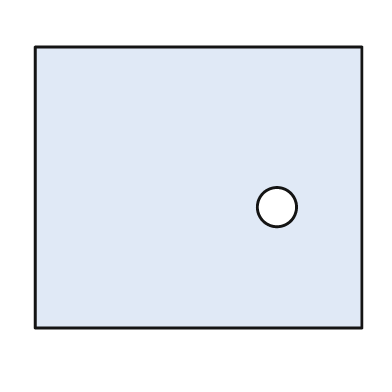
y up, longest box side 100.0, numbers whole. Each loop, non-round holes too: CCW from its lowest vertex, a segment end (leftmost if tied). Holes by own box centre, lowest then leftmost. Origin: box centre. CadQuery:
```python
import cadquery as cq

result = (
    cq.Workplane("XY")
    .moveTo(-50.0, -43.0)
    .lineTo(50.0, -43.0)
    .lineTo(50.0, 43.0)
    .lineTo(-50.0, 43.0)
    .close()
    .moveTo(24.0, -6.0)
    .circle(6.0)
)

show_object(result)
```